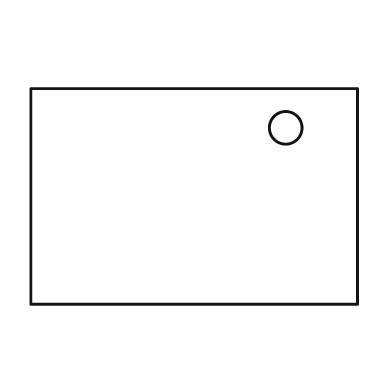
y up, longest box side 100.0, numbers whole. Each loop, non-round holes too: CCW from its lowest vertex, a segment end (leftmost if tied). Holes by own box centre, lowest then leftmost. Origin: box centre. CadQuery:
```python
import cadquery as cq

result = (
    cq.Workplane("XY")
    .moveTo(-50.0, -33.0)
    .lineTo(50.0, -33.0)
    .lineTo(50.0, 33.0)
    .lineTo(-50.0, 33.0)
    .close()
    .moveTo(28.0, 21.0)
    .circle(5.0)
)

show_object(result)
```